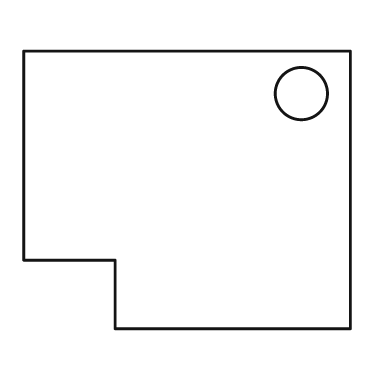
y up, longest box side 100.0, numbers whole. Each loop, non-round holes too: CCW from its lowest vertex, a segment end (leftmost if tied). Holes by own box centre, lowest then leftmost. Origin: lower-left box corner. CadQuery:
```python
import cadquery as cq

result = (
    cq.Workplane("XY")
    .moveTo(28.0, 0.0)
    .lineTo(100.0, 0.0)
    .lineTo(100.0, 85.0)
    .lineTo(0.0, 85.0)
    .lineTo(0.0, 21.0)
    .lineTo(28.0, 21.0)
    .close()
    .moveTo(85.0, 72.0)
    .circle(8.0)
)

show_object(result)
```